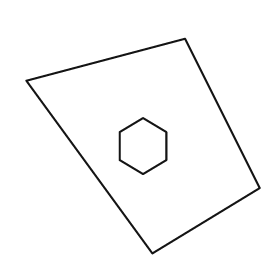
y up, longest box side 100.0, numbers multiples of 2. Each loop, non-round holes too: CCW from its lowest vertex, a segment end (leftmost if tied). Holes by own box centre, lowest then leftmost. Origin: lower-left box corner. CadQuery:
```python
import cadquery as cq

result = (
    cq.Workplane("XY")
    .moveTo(54.0, 0.0)
    .lineTo(100.0, 28.0)
    .lineTo(68.0, 92.0)
    .lineTo(0.0, 74.0)
    .close()
    .moveTo(50.0, 34.0)
    .lineTo(60.0, 40.0)
    .lineTo(60.0, 52.0)
    .lineTo(50.0, 58.0)
    .lineTo(40.0, 52.0)
    .lineTo(40.0, 40.0)
    .close()
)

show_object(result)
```